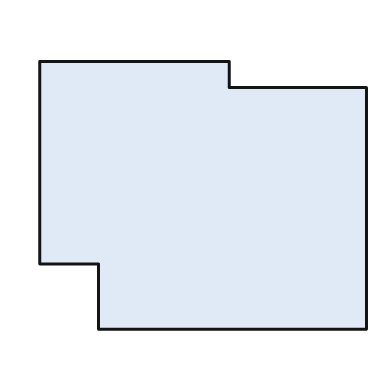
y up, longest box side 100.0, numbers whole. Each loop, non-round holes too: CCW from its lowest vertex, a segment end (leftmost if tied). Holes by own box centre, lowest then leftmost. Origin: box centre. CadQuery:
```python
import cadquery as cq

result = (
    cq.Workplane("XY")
    .moveTo(-32.0, -41.0)
    .lineTo(50.0, -41.0)
    .lineTo(50.0, 33.0)
    .lineTo(8.0, 33.0)
    .lineTo(8.0, 41.0)
    .lineTo(-50.0, 41.0)
    .lineTo(-50.0, -21.0)
    .lineTo(-32.0, -21.0)
    .close()
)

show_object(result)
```